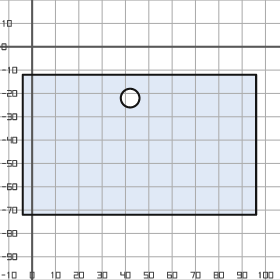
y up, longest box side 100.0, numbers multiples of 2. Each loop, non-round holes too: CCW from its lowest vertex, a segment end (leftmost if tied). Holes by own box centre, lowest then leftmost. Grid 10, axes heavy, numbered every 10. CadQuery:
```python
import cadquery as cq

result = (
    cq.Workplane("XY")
    .moveTo(-4.0, -72.0)
    .lineTo(96.0, -72.0)
    .lineTo(96.0, -12.0)
    .lineTo(-4.0, -12.0)
    .close()
    .moveTo(42.0, -22.0)
    .circle(4.0)
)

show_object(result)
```